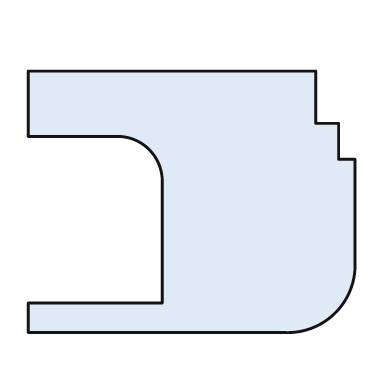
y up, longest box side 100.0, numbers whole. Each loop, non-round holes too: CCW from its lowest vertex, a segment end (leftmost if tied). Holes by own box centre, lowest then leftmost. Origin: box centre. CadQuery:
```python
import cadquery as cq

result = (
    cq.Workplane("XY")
    .moveTo(-50.0, -40.0)
    .lineTo(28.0, -40.0)
    .threePointArc((44.0, -34.0), (50.0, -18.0))
    .lineTo(50.0, 13.0)
    .lineTo(45.0, 13.0)
    .lineTo(45.0, 24.0)
    .lineTo(38.0, 24.0)
    .lineTo(38.0, 40.0)
    .lineTo(-50.0, 40.0)
    .lineTo(-50.0, 20.0)
    .lineTo(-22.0, 20.0)
    .threePointArc((-13.0, 16.0), (-9.0, 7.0))
    .lineTo(-9.0, -31.0)
    .lineTo(-50.0, -31.0)
    .close()
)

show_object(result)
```